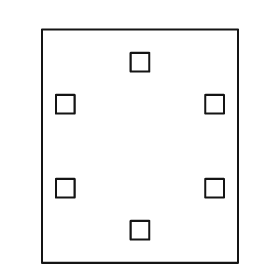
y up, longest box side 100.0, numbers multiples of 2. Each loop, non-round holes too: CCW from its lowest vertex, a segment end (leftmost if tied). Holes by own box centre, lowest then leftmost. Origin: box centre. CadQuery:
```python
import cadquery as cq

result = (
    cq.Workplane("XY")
    .moveTo(-42.0, -50.0)
    .lineTo(42.0, -50.0)
    .lineTo(42.0, 50.0)
    .lineTo(-42.0, 50.0)
    .close()
    .moveTo(-4.0, -40.0)
    .lineTo(4.0, -40.0)
    .lineTo(4.0, -32.0)
    .lineTo(-4.0, -32.0)
    .close()
    .moveTo(-36.0, -22.0)
    .lineTo(-28.0, -22.0)
    .lineTo(-28.0, -14.0)
    .lineTo(-36.0, -14.0)
    .close()
    .moveTo(28.0, -22.0)
    .lineTo(36.0, -22.0)
    .lineTo(36.0, -14.0)
    .lineTo(28.0, -14.0)
    .close()
    .moveTo(-36.0, 14.0)
    .lineTo(-28.0, 14.0)
    .lineTo(-28.0, 22.0)
    .lineTo(-36.0, 22.0)
    .close()
    .moveTo(28.0, 14.0)
    .lineTo(36.0, 14.0)
    .lineTo(36.0, 22.0)
    .lineTo(28.0, 22.0)
    .close()
    .moveTo(-4.0, 32.0)
    .lineTo(4.0, 32.0)
    .lineTo(4.0, 40.0)
    .lineTo(-4.0, 40.0)
    .close()
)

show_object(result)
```